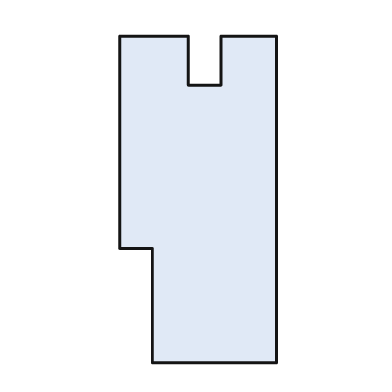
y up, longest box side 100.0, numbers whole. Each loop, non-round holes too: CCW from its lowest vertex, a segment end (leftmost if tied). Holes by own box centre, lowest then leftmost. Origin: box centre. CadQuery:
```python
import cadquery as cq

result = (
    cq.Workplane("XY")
    .moveTo(-14.0, -50.0)
    .lineTo(24.0, -50.0)
    .lineTo(24.0, 50.0)
    .lineTo(7.0, 50.0)
    .lineTo(7.0, 35.0)
    .lineTo(-3.0, 35.0)
    .lineTo(-3.0, 50.0)
    .lineTo(-24.0, 50.0)
    .lineTo(-24.0, -15.0)
    .lineTo(-14.0, -15.0)
    .close()
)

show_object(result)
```